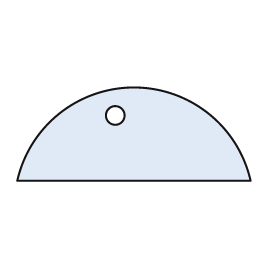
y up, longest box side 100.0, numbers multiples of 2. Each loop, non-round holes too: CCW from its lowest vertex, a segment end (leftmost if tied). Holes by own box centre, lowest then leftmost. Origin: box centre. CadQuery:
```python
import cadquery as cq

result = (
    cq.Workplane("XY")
    .moveTo(-50.0, -20.0)
    .lineTo(50.0, -20.0)
    .threePointArc((0.0, 20.0), (-50.0, -20.0))
    .close()
    .moveTo(-8.0, 8.0)
    .circle(4.0)
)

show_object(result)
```